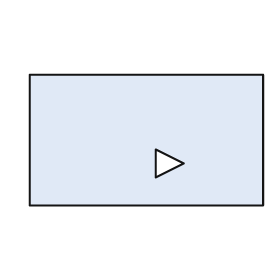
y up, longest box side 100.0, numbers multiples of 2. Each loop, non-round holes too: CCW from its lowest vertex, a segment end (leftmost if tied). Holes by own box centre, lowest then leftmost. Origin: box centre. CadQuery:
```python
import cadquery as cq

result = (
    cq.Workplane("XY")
    .moveTo(-50.0, -28.0)
    .lineTo(50.0, -28.0)
    .lineTo(50.0, 28.0)
    .lineTo(-50.0, 28.0)
    .close()
    .moveTo(4.0, -16.0)
    .lineTo(16.0, -10.0)
    .lineTo(4.0, -4.0)
    .close()
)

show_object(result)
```